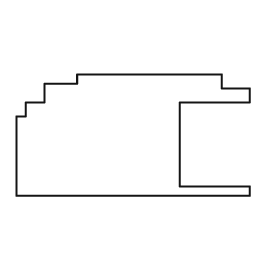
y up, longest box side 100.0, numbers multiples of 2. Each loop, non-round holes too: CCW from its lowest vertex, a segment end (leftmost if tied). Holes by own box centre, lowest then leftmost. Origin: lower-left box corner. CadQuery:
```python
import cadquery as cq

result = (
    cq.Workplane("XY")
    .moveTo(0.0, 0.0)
    .lineTo(100.0, 0.0)
    .lineTo(100.0, 4.0)
    .lineTo(70.0, 4.0)
    .lineTo(70.0, 40.0)
    .lineTo(100.0, 40.0)
    .lineTo(100.0, 46.0)
    .lineTo(88.0, 46.0)
    .lineTo(88.0, 52.0)
    .lineTo(26.0, 52.0)
    .lineTo(26.0, 48.0)
    .lineTo(12.0, 48.0)
    .lineTo(12.0, 40.0)
    .lineTo(4.0, 40.0)
    .lineTo(4.0, 34.0)
    .lineTo(0.0, 34.0)
    .close()
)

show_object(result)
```